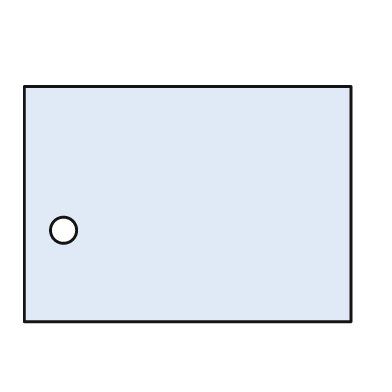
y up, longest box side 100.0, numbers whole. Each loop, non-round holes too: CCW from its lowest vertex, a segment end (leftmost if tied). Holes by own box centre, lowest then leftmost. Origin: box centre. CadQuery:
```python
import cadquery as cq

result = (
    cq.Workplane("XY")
    .moveTo(-50.0, -36.0)
    .lineTo(50.0, -36.0)
    .lineTo(50.0, 36.0)
    .lineTo(-50.0, 36.0)
    .close()
    .moveTo(-38.0, -8.0)
    .circle(4.0)
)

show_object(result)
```